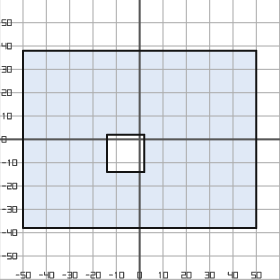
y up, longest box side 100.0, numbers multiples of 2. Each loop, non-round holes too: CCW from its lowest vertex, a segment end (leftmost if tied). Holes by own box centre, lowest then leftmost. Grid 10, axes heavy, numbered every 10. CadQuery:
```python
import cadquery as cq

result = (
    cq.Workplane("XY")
    .moveTo(-50.0, -38.0)
    .lineTo(50.0, -38.0)
    .lineTo(50.0, 38.0)
    .lineTo(-50.0, 38.0)
    .close()
    .moveTo(-14.0, -14.0)
    .lineTo(2.0, -14.0)
    .lineTo(2.0, 2.0)
    .lineTo(-14.0, 2.0)
    .close()
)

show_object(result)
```